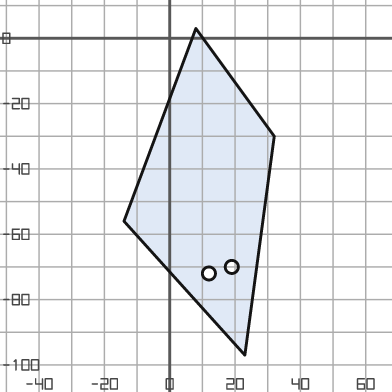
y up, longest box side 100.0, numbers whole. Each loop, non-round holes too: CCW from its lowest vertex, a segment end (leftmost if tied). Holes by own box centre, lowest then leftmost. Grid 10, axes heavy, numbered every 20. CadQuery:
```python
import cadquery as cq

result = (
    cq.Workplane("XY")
    .moveTo(23.0, -97.0)
    .lineTo(32.0, -30.0)
    .lineTo(8.0, 3.0)
    .lineTo(-14.0, -56.0)
    .close()
    .moveTo(12.0, -72.0)
    .circle(2.0)
    .moveTo(19.0, -70.0)
    .circle(2.0)
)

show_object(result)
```